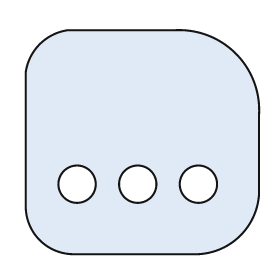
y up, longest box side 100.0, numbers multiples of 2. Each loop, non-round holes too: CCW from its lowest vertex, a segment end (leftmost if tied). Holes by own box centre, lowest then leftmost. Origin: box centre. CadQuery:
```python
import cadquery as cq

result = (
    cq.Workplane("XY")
    .moveTo(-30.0, -48.0)
    .lineTo(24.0, -48.0)
    .threePointArc((42.0, -40.0), (50.0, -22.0))
    .lineTo(50.0, 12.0)
    .threePointArc((40.0, 38.0), (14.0, 48.0))
    .lineTo(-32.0, 48.0)
    .threePointArc((-44.0, 42.0), (-50.0, 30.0))
    .lineTo(-50.0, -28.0)
    .threePointArc((-44.0, -42.0), (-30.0, -48.0))
    .close()
    .moveTo(-28.0, -18.0)
    .circle(8.0)
    .moveTo(-2.0, -18.0)
    .circle(8.0)
    .moveTo(24.0, -18.0)
    .circle(8.0)
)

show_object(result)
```